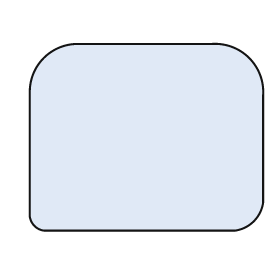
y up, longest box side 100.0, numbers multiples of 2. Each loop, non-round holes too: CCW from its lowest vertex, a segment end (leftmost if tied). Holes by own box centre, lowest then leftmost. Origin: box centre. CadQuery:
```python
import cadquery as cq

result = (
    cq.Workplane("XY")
    .moveTo(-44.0, -40.0)
    .lineTo(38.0, -40.0)
    .threePointArc((46.0, -36.0), (50.0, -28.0))
    .lineTo(50.0, 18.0)
    .threePointArc((44.0, 34.0), (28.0, 40.0))
    .lineTo(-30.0, 40.0)
    .threePointArc((-44.0, 34.0), (-50.0, 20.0))
    .lineTo(-50.0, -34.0)
    .threePointArc((-48.0, -38.0), (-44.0, -40.0))
    .close()
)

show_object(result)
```